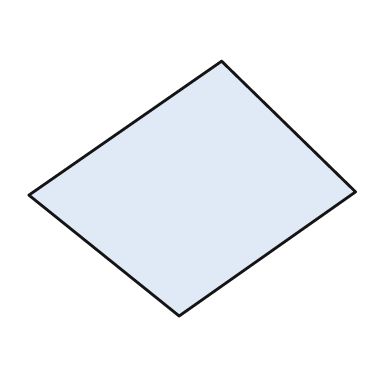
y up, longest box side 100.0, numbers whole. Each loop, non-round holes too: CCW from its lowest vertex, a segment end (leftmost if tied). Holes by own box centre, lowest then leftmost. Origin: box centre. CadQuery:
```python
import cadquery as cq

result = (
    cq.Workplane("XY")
    .moveTo(-4.0, -39.0)
    .lineTo(50.0, -1.0)
    .lineTo(9.0, 39.0)
    .lineTo(-50.0, -2.0)
    .close()
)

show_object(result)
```